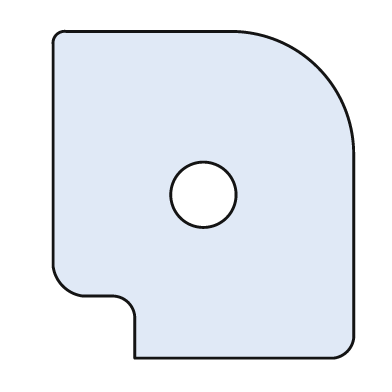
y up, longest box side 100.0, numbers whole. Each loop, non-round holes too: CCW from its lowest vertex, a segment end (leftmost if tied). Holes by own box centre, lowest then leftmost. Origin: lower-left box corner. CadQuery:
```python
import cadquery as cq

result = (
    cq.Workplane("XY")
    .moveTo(25.0, 0.0)
    .lineTo(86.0, 0.0)
    .threePointArc((90.0, 2.0), (92.0, 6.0))
    .lineTo(92.0, 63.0)
    .threePointArc((81.0, 89.0), (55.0, 100.0))
    .lineTo(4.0, 100.0)
    .threePointArc((1.0, 99.0), (0.0, 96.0))
    .lineTo(0.0, 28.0)
    .threePointArc((3.0, 22.0), (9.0, 19.0))
    .lineTo(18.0, 19.0)
    .threePointArc((23.0, 17.0), (25.0, 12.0))
    .close()
    .moveTo(46.0, 50.0)
    .circle(10.0)
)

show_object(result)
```